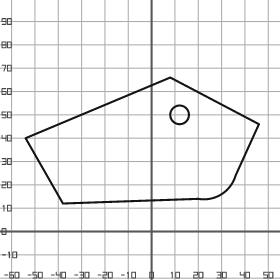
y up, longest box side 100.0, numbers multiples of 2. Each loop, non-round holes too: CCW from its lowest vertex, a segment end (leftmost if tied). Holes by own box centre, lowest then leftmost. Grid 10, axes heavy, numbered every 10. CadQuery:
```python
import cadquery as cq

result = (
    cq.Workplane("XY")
    .moveTo(-38.0, 12.0)
    .lineTo(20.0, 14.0)
    .threePointArc((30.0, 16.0), (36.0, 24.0))
    .lineTo(46.0, 46.0)
    .lineTo(8.0, 66.0)
    .lineTo(-54.0, 40.0)
    .close()
    .moveTo(12.0, 50.0)
    .circle(4.0)
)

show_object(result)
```